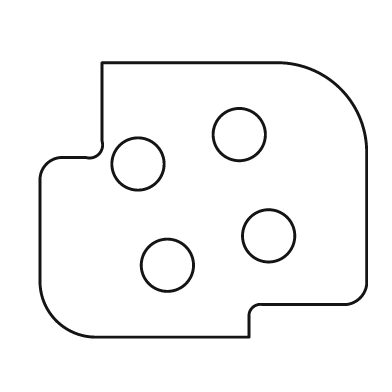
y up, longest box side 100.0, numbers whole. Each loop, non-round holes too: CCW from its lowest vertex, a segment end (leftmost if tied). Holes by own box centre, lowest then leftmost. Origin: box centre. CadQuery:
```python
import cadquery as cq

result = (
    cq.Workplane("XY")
    .moveTo(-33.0, -42.0)
    .lineTo(14.0, -42.0)
    .lineTo(14.0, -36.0)
    .threePointArc((15.0, -33.0), (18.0, -32.0))
    .lineTo(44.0, -32.0)
    .threePointArc((48.0, -30.0), (50.0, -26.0))
    .lineTo(50.0, 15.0)
    .threePointArc((42.0, 34.0), (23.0, 42.0))
    .lineTo(-31.0, 42.0)
    .lineTo(-31.0, 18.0)
    .threePointArc((-32.0, 14.0), (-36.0, 13.0))
    .lineTo(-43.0, 13.0)
    .threePointArc((-48.0, 11.0), (-50.0, 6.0))
    .lineTo(-50.0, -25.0)
    .threePointArc((-45.0, -37.0), (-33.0, -42.0))
    .close()
    .moveTo(-11.0, -20.0)
    .circle(8.0)
    .moveTo(20.0, -11.0)
    .circle(8.0)
    .moveTo(-20.0, 11.0)
    .circle(8.0)
    .moveTo(11.0, 20.0)
    .circle(8.0)
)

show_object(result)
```